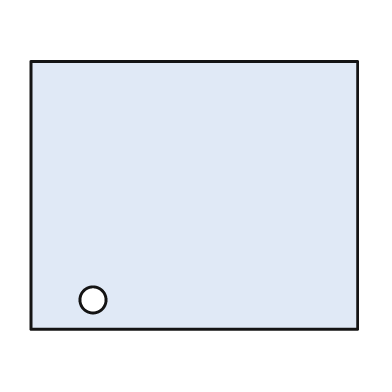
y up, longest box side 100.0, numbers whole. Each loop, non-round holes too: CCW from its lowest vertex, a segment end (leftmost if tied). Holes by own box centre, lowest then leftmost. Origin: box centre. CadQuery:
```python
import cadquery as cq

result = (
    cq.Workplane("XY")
    .moveTo(-50.0, -41.0)
    .lineTo(50.0, -41.0)
    .lineTo(50.0, 41.0)
    .lineTo(-50.0, 41.0)
    .close()
    .moveTo(-31.0, -32.0)
    .circle(4.0)
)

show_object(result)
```